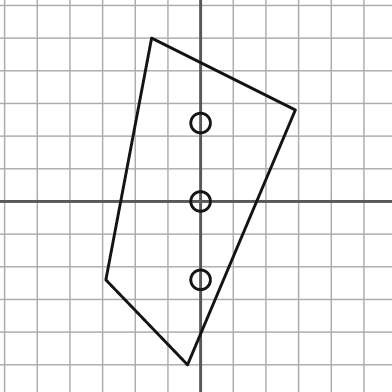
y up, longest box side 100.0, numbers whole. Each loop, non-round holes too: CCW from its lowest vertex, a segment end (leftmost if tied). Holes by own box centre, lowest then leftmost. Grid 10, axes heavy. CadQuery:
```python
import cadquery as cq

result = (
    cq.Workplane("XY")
    .moveTo(-4.0, -50.0)
    .lineTo(29.0, 28.0)
    .lineTo(-15.0, 50.0)
    .lineTo(-29.0, -24.0)
    .close()
    .moveTo(0.0, -24.0)
    .circle(3.0)
    .moveTo(0.0, 0.0)
    .circle(3.0)
    .moveTo(0.0, 24.0)
    .circle(3.0)
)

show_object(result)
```